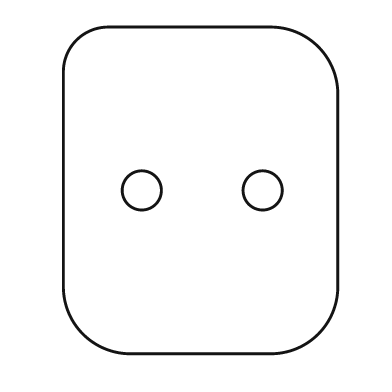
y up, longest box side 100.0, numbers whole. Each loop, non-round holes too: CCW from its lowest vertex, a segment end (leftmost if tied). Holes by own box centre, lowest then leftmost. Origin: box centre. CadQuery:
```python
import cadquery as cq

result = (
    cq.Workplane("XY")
    .moveTo(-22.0, -50.0)
    .lineTo(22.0, -50.0)
    .threePointArc((36.0, -44.0), (42.0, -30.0))
    .lineTo(42.0, 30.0)
    .threePointArc((36.0, 44.0), (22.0, 50.0))
    .lineTo(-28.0, 50.0)
    .threePointArc((-38.0, 46.0), (-42.0, 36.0))
    .lineTo(-42.0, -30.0)
    .threePointArc((-36.0, -44.0), (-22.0, -50.0))
    .close()
    .moveTo(-18.0, 0.0)
    .circle(6.0)
    .moveTo(19.0, 0.0)
    .circle(6.0)
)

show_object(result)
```